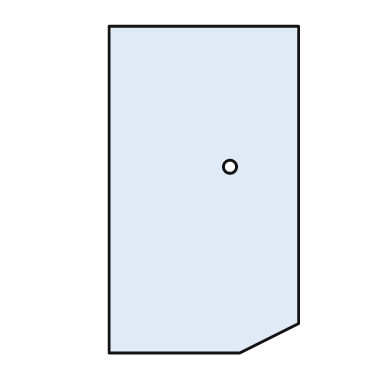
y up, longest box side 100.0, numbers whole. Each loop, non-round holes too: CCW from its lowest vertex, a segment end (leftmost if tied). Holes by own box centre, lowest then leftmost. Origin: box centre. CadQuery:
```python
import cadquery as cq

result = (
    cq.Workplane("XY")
    .moveTo(-29.0, -50.0)
    .lineTo(11.0, -50.0)
    .lineTo(29.0, -41.0)
    .lineTo(29.0, 50.0)
    .lineTo(-29.0, 50.0)
    .close()
    .moveTo(8.0, 7.0)
    .circle(2.0)
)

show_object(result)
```